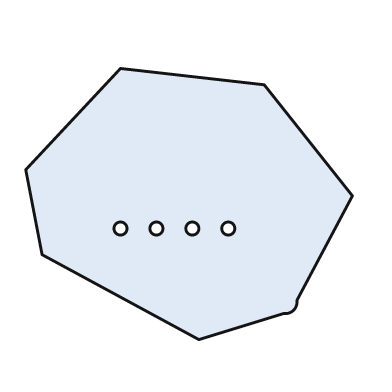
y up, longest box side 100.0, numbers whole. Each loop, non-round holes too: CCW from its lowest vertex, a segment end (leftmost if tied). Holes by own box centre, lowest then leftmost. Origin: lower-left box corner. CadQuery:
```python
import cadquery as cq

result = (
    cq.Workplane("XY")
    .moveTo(53.0, 0.0)
    .lineTo(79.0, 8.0)
    .threePointArc((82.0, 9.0), (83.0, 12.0))
    .lineTo(100.0, 44.0)
    .lineTo(73.0, 78.0)
    .lineTo(29.0, 83.0)
    .lineTo(0.0, 52.0)
    .lineTo(5.0, 26.0)
    .close()
    .moveTo(29.0, 34.0)
    .circle(2.0)
    .moveTo(40.0, 34.0)
    .circle(2.0)
    .moveTo(51.0, 34.0)
    .circle(2.0)
    .moveTo(62.0, 34.0)
    .circle(2.0)
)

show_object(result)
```